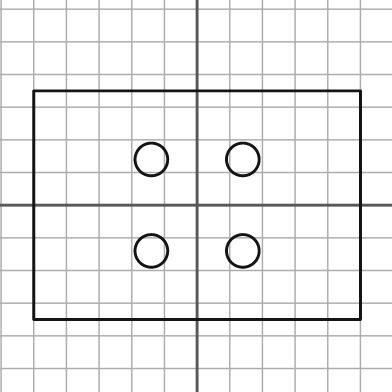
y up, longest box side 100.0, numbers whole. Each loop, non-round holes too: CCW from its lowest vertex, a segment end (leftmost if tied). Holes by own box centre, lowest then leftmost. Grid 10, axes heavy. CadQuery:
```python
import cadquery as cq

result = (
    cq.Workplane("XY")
    .moveTo(-50.0, -35.0)
    .lineTo(50.0, -35.0)
    .lineTo(50.0, 35.0)
    .lineTo(-50.0, 35.0)
    .close()
    .moveTo(-14.0, -14.0)
    .circle(5.0)
    .moveTo(14.0, -14.0)
    .circle(5.0)
    .moveTo(-14.0, 14.0)
    .circle(5.0)
    .moveTo(14.0, 14.0)
    .circle(5.0)
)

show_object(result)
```